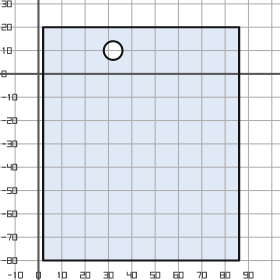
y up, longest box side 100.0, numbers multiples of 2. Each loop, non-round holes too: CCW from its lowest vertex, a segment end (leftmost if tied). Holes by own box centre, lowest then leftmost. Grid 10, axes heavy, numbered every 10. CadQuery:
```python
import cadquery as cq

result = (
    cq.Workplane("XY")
    .moveTo(2.0, -80.0)
    .lineTo(86.0, -80.0)
    .lineTo(86.0, 20.0)
    .lineTo(2.0, 20.0)
    .close()
    .moveTo(32.0, 10.0)
    .circle(4.0)
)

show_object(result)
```